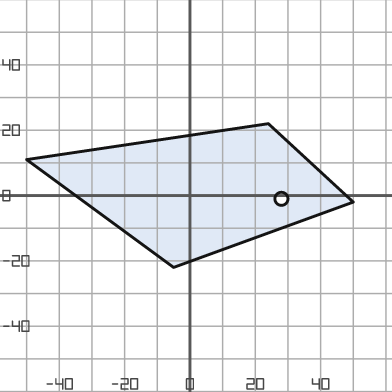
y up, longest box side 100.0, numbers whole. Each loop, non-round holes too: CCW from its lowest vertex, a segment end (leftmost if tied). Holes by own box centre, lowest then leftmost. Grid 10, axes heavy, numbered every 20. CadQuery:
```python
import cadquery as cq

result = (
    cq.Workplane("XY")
    .moveTo(-5.0, -22.0)
    .lineTo(50.0, -2.0)
    .lineTo(24.0, 22.0)
    .lineTo(-50.0, 11.0)
    .close()
    .moveTo(28.0, -1.0)
    .circle(2.0)
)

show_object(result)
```